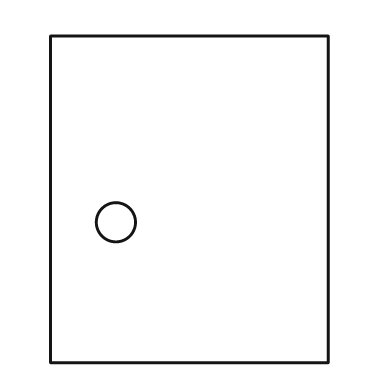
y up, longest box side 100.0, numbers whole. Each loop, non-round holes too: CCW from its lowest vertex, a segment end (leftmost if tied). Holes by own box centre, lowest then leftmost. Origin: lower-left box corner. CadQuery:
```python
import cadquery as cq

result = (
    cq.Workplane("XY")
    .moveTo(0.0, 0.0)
    .lineTo(85.0, 0.0)
    .lineTo(85.0, 100.0)
    .lineTo(0.0, 100.0)
    .close()
    .moveTo(20.0, 43.0)
    .circle(6.0)
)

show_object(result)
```